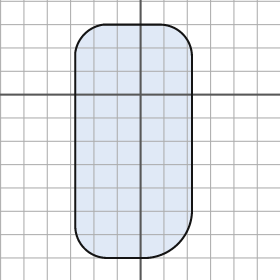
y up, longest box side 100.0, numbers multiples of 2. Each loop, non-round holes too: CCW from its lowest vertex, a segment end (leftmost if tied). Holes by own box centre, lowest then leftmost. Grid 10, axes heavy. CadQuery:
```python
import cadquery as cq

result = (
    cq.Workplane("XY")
    .moveTo(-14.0, -70.0)
    .lineTo(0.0, -70.0)
    .threePointArc((16.0, -64.0), (22.0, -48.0))
    .lineTo(22.0, 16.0)
    .threePointArc((18.0, 26.0), (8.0, 30.0))
    .lineTo(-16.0, 30.0)
    .threePointArc((-24.0, 26.0), (-28.0, 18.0))
    .lineTo(-28.0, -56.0)
    .threePointArc((-24.0, -66.0), (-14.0, -70.0))
    .close()
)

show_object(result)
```